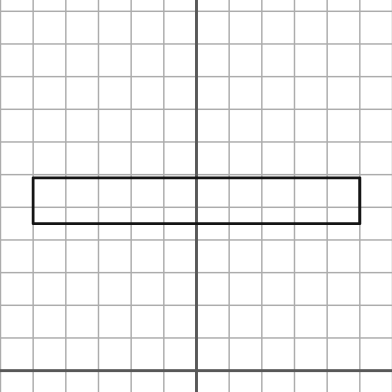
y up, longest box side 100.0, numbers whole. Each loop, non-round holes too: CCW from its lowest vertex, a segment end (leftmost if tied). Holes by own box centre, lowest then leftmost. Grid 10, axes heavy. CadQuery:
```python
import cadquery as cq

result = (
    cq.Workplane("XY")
    .moveTo(-50.0, 45.0)
    .lineTo(50.0, 45.0)
    .lineTo(50.0, 59.0)
    .lineTo(-50.0, 59.0)
    .close()
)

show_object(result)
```